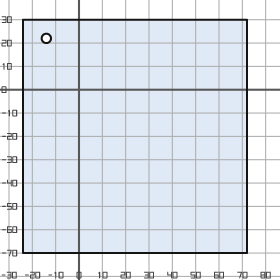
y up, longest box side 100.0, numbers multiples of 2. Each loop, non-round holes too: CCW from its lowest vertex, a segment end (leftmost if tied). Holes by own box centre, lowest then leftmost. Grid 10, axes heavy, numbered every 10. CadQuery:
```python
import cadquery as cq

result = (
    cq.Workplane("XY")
    .moveTo(-24.0, -70.0)
    .lineTo(72.0, -70.0)
    .lineTo(72.0, 30.0)
    .lineTo(-24.0, 30.0)
    .close()
    .moveTo(-14.0, 22.0)
    .circle(2.0)
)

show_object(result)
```